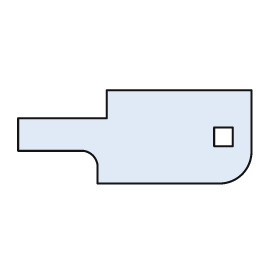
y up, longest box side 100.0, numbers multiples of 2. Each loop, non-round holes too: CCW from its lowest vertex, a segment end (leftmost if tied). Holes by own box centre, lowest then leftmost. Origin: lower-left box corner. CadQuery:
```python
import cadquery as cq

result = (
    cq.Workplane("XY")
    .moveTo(34.0, 0.0)
    .lineTo(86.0, 0.0)
    .threePointArc((96.0, 4.0), (100.0, 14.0))
    .lineTo(100.0, 40.0)
    .lineTo(38.0, 40.0)
    .lineTo(38.0, 28.0)
    .lineTo(0.0, 28.0)
    .lineTo(0.0, 14.0)
    .lineTo(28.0, 14.0)
    .threePointArc((32.0, 12.0), (34.0, 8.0))
    .close()
    .moveTo(84.0, 16.0)
    .lineTo(92.0, 16.0)
    .lineTo(92.0, 24.0)
    .lineTo(84.0, 24.0)
    .close()
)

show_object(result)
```